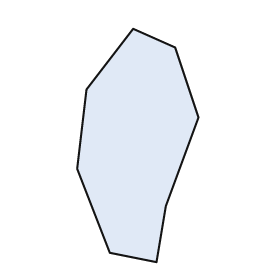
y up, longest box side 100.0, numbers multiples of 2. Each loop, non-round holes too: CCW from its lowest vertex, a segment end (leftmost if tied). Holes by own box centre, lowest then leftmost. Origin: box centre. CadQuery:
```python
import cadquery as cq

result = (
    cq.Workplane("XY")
    .moveTo(8.0, -50.0)
    .lineTo(12.0, -26.0)
    .lineTo(26.0, 12.0)
    .lineTo(16.0, 42.0)
    .lineTo(-2.0, 50.0)
    .lineTo(-22.0, 24.0)
    .lineTo(-26.0, -10.0)
    .lineTo(-12.0, -46.0)
    .close()
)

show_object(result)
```